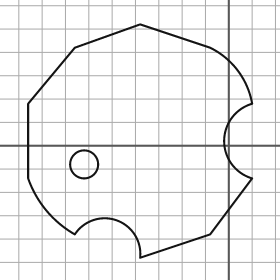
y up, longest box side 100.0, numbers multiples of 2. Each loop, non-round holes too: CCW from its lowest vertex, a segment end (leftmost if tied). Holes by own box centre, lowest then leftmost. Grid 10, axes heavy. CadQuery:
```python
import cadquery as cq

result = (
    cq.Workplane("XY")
    .moveTo(-38.0, -48.0)
    .lineTo(-8.0, -38.0)
    .lineTo(10.0, -14.0)
    .threePointArc((-2.0, 2.0), (10.0, 18.0))
    .threePointArc((4.0, 32.0), (-8.0, 42.0))
    .lineTo(-38.0, 52.0)
    .lineTo(-66.0, 42.0)
    .lineTo(-86.0, 18.0)
    .lineTo(-86.0, -14.0)
    .threePointArc((-78.0, -28.0), (-66.0, -38.0))
    .threePointArc((-48.0, -32.0), (-38.0, -48.0))
    .close()
    .moveTo(-62.0, -8.0)
    .circle(6.0)
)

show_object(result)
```